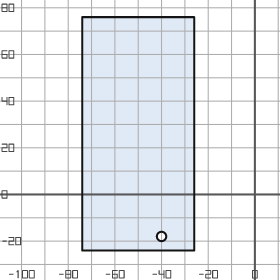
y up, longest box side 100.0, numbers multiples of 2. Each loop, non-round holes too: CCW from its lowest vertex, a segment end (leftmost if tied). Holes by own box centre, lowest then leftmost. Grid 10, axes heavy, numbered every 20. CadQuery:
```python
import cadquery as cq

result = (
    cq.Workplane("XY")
    .moveTo(-74.0, -24.0)
    .lineTo(-26.0, -24.0)
    .lineTo(-26.0, 76.0)
    .lineTo(-74.0, 76.0)
    .close()
    .moveTo(-40.0, -18.0)
    .circle(2.0)
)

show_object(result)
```